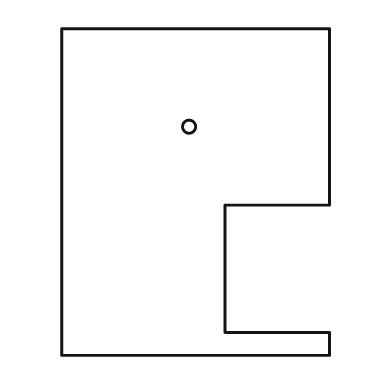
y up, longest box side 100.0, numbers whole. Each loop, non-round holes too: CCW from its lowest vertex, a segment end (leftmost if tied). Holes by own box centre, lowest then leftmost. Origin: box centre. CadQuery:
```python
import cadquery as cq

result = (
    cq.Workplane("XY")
    .moveTo(-41.0, -50.0)
    .lineTo(41.0, -50.0)
    .lineTo(41.0, -43.0)
    .lineTo(9.0, -43.0)
    .lineTo(9.0, -4.0)
    .lineTo(41.0, -4.0)
    .lineTo(41.0, 50.0)
    .lineTo(-41.0, 50.0)
    .close()
    .moveTo(-2.0, 20.0)
    .circle(2.0)
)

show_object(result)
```